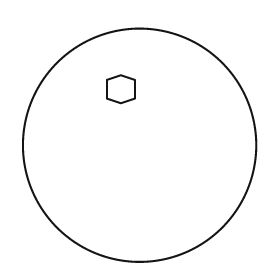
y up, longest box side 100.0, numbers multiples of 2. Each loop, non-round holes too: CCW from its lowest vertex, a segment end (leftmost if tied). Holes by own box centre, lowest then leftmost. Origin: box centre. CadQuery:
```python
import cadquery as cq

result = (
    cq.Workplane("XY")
    .moveTo(0.0, 0.0)
    .circle(50.0)
    .moveTo(-8.0, 18.0)
    .lineTo(-2.0, 20.0)
    .lineTo(-2.0, 28.0)
    .lineTo(-8.0, 30.0)
    .lineTo(-14.0, 28.0)
    .lineTo(-14.0, 20.0)
    .close()
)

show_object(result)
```